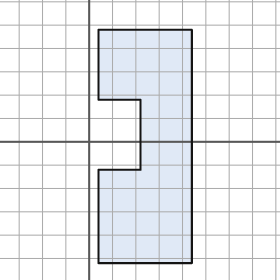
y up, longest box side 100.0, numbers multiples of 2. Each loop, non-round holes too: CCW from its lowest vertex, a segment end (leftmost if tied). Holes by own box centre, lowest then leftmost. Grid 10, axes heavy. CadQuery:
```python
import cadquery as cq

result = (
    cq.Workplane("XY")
    .moveTo(4.0, -52.0)
    .lineTo(44.0, -52.0)
    .lineTo(44.0, 48.0)
    .lineTo(4.0, 48.0)
    .lineTo(4.0, 18.0)
    .lineTo(22.0, 18.0)
    .lineTo(22.0, -12.0)
    .lineTo(4.0, -12.0)
    .close()
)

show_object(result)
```